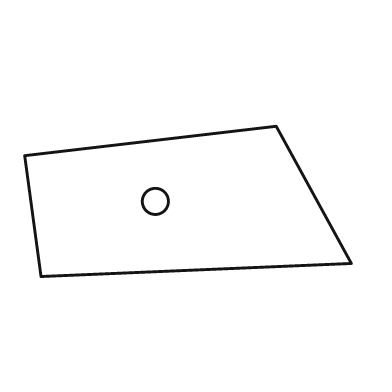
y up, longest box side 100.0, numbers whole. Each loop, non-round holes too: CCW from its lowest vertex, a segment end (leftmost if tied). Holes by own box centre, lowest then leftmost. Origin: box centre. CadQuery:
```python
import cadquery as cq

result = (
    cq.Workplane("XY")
    .moveTo(-45.0, -23.0)
    .lineTo(50.0, -19.0)
    .lineTo(27.0, 23.0)
    .lineTo(-50.0, 14.0)
    .close()
    .moveTo(-10.0, 0.0)
    .circle(4.0)
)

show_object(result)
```